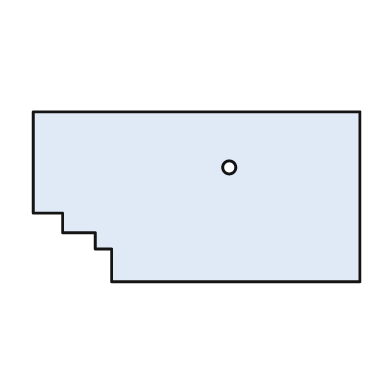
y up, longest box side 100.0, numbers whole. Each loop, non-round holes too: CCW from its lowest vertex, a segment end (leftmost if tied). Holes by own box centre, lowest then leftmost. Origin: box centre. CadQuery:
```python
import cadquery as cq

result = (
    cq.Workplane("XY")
    .moveTo(-26.0, -26.0)
    .lineTo(50.0, -26.0)
    .lineTo(50.0, 26.0)
    .lineTo(-50.0, 26.0)
    .lineTo(-50.0, -5.0)
    .lineTo(-41.0, -5.0)
    .lineTo(-41.0, -11.0)
    .lineTo(-31.0, -11.0)
    .lineTo(-31.0, -16.0)
    .lineTo(-26.0, -16.0)
    .close()
    .moveTo(10.0, 9.0)
    .circle(2.0)
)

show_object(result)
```